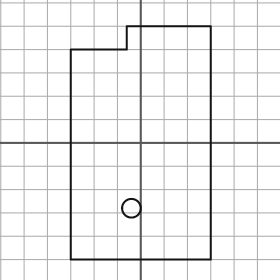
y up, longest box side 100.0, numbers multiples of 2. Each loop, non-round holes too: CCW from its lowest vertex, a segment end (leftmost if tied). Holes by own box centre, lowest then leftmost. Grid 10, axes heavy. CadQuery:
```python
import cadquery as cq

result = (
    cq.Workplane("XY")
    .moveTo(-30.0, -50.0)
    .lineTo(30.0, -50.0)
    .lineTo(30.0, 50.0)
    .lineTo(-6.0, 50.0)
    .lineTo(-6.0, 40.0)
    .lineTo(-30.0, 40.0)
    .close()
    .moveTo(-4.0, -28.0)
    .circle(4.0)
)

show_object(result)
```